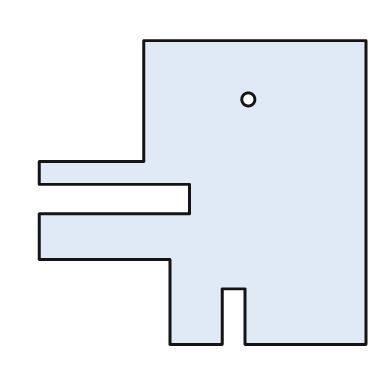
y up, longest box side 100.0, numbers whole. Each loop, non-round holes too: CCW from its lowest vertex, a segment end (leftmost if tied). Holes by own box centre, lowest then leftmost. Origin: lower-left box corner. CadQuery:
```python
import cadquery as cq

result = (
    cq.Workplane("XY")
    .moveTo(40.0, 0.0)
    .lineTo(56.0, 0.0)
    .lineTo(56.0, 17.0)
    .lineTo(63.0, 17.0)
    .lineTo(63.0, 0.0)
    .lineTo(100.0, 0.0)
    .lineTo(100.0, 93.0)
    .lineTo(32.0, 93.0)
    .lineTo(32.0, 56.0)
    .lineTo(0.0, 56.0)
    .lineTo(0.0, 49.0)
    .lineTo(46.0, 49.0)
    .lineTo(46.0, 40.0)
    .lineTo(0.0, 40.0)
    .lineTo(0.0, 26.0)
    .lineTo(40.0, 26.0)
    .close()
    .moveTo(64.0, 75.0)
    .circle(2.0)
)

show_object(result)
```